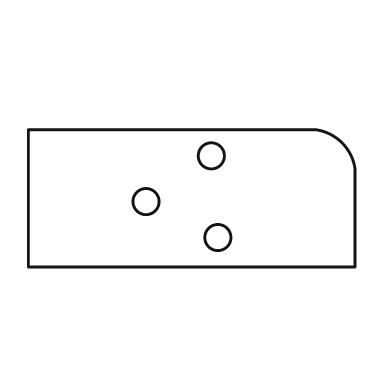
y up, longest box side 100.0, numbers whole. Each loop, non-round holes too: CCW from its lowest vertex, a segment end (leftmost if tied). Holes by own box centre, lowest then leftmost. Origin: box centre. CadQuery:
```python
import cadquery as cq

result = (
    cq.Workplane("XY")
    .moveTo(-50.0, -21.0)
    .lineTo(50.0, -21.0)
    .lineTo(50.0, 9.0)
    .threePointArc((46.0, 17.0), (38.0, 21.0))
    .lineTo(-50.0, 21.0)
    .close()
    .moveTo(8.0, -12.0)
    .circle(4.0)
    .moveTo(-14.0, -1.0)
    .circle(4.0)
    .moveTo(6.0, 13.0)
    .circle(4.0)
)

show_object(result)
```